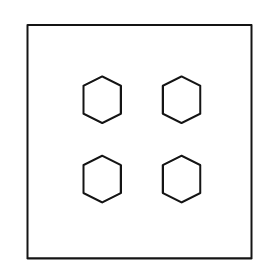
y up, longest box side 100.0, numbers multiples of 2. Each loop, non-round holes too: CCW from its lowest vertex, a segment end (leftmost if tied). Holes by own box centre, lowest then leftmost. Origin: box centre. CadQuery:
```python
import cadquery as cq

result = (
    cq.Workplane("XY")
    .moveTo(-48.0, -50.0)
    .lineTo(48.0, -50.0)
    .lineTo(48.0, 50.0)
    .lineTo(-48.0, 50.0)
    .close()
    .moveTo(-16.0, -26.0)
    .lineTo(-8.0, -22.0)
    .lineTo(-8.0, -10.0)
    .lineTo(-16.0, -6.0)
    .lineTo(-24.0, -10.0)
    .lineTo(-24.0, -22.0)
    .close()
    .moveTo(18.0, -26.0)
    .lineTo(26.0, -22.0)
    .lineTo(26.0, -10.0)
    .lineTo(18.0, -6.0)
    .lineTo(10.0, -10.0)
    .lineTo(10.0, -22.0)
    .close()
    .moveTo(-16.0, 8.0)
    .lineTo(-8.0, 12.0)
    .lineTo(-8.0, 24.0)
    .lineTo(-16.0, 28.0)
    .lineTo(-24.0, 24.0)
    .lineTo(-24.0, 12.0)
    .close()
    .moveTo(18.0, 8.0)
    .lineTo(26.0, 12.0)
    .lineTo(26.0, 24.0)
    .lineTo(18.0, 28.0)
    .lineTo(10.0, 24.0)
    .lineTo(10.0, 12.0)
    .close()
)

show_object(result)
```